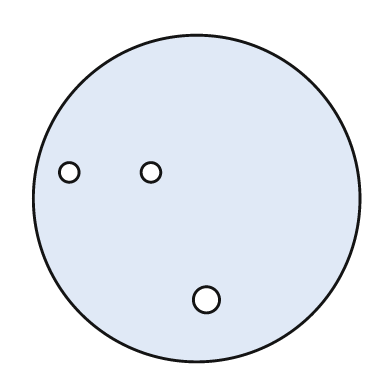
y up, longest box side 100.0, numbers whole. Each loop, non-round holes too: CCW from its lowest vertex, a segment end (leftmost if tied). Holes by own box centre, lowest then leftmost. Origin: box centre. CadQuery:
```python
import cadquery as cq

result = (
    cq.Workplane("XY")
    .moveTo(0.0, 0.0)
    .circle(50.0)
    .moveTo(3.0, -31.0)
    .circle(4.0)
    .moveTo(-39.0, 8.0)
    .circle(3.0)
    .moveTo(-14.0, 8.0)
    .circle(3.0)
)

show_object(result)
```